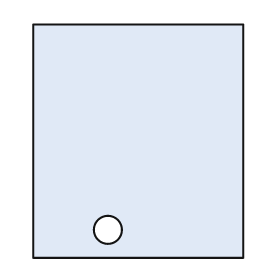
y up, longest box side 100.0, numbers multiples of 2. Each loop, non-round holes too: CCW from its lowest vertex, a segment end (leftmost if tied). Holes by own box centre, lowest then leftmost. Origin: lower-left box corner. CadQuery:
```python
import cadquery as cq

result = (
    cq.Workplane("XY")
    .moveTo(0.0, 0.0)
    .lineTo(90.0, 0.0)
    .lineTo(90.0, 100.0)
    .lineTo(0.0, 100.0)
    .close()
    .moveTo(32.0, 12.0)
    .circle(6.0)
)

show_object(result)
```